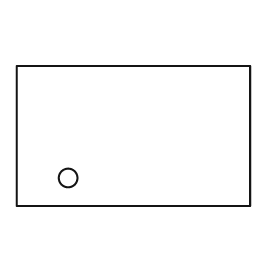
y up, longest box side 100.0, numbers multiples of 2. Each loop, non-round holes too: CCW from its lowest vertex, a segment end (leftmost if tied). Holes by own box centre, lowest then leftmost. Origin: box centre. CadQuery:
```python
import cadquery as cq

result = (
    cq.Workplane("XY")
    .moveTo(-50.0, -30.0)
    .lineTo(50.0, -30.0)
    .lineTo(50.0, 30.0)
    .lineTo(-50.0, 30.0)
    .close()
    .moveTo(-28.0, -18.0)
    .circle(4.0)
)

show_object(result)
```